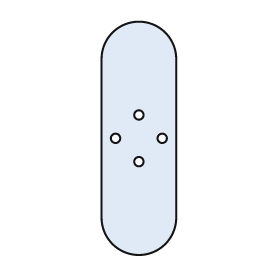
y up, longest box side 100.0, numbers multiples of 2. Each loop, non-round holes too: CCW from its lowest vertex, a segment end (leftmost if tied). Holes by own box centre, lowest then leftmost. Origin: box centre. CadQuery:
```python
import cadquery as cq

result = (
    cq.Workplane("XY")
    .moveTo(-16.0, -34.0)
    .threePointArc((0.0, -50.0), (16.0, -34.0))
    .lineTo(16.0, 34.0)
    .threePointArc((0.0, 50.0), (-16.0, 34.0))
    .close()
    .moveTo(0.0, -10.0)
    .circle(2.0)
    .moveTo(-10.0, 0.0)
    .circle(2.0)
    .moveTo(10.0, 0.0)
    .circle(2.0)
    .moveTo(0.0, 10.0)
    .circle(2.0)
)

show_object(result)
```